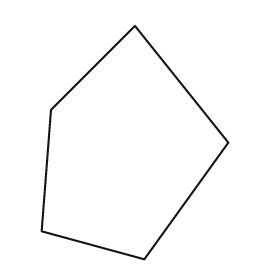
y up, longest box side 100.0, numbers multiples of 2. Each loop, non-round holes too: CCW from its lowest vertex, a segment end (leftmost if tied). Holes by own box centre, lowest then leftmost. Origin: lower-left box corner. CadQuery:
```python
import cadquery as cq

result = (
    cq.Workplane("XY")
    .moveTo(44.0, 0.0)
    .lineTo(80.0, 50.0)
    .lineTo(40.0, 100.0)
    .lineTo(4.0, 64.0)
    .lineTo(0.0, 12.0)
    .close()
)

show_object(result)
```